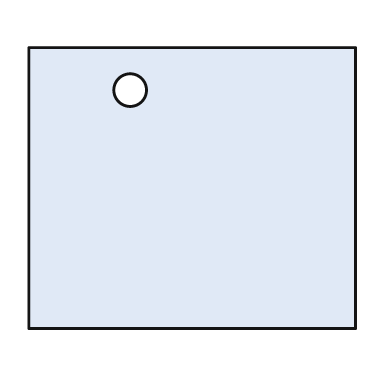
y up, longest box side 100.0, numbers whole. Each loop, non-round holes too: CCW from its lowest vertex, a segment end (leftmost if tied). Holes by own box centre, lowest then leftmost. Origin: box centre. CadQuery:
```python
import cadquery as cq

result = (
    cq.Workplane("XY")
    .moveTo(-50.0, -43.0)
    .lineTo(50.0, -43.0)
    .lineTo(50.0, 43.0)
    .lineTo(-50.0, 43.0)
    .close()
    .moveTo(-19.0, 30.0)
    .circle(5.0)
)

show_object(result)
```